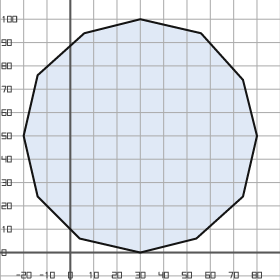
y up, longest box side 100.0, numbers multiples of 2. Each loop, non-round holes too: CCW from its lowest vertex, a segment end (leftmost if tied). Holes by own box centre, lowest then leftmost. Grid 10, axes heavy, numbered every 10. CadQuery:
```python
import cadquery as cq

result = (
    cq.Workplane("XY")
    .moveTo(30.0, 0.0)
    .lineTo(54.0, 6.0)
    .lineTo(74.0, 24.0)
    .lineTo(80.0, 50.0)
    .lineTo(74.0, 74.0)
    .lineTo(56.0, 94.0)
    .lineTo(30.0, 100.0)
    .lineTo(6.0, 94.0)
    .lineTo(-14.0, 76.0)
    .lineTo(-20.0, 50.0)
    .lineTo(-14.0, 24.0)
    .lineTo(4.0, 6.0)
    .close()
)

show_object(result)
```